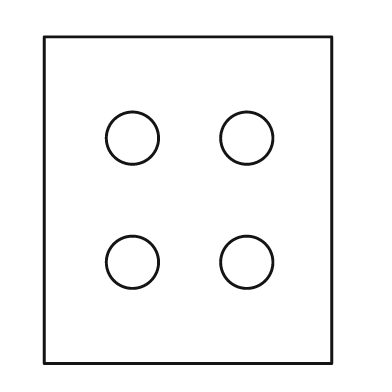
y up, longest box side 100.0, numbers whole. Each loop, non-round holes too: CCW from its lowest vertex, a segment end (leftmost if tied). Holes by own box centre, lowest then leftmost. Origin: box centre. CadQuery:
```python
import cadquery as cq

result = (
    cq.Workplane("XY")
    .moveTo(-44.0, -50.0)
    .lineTo(44.0, -50.0)
    .lineTo(44.0, 50.0)
    .lineTo(-44.0, 50.0)
    .close()
    .moveTo(-17.0, -19.0)
    .circle(8.0)
    .moveTo(18.0, -19.0)
    .circle(8.0)
    .moveTo(-17.0, 19.0)
    .circle(8.0)
    .moveTo(18.0, 19.0)
    .circle(8.0)
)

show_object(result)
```